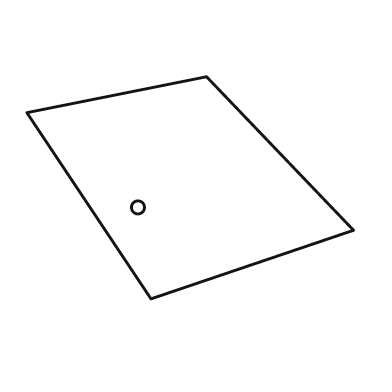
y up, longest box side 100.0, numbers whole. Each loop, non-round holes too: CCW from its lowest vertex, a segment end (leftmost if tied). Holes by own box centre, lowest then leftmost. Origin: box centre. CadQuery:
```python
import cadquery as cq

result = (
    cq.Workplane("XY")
    .moveTo(-12.0, -34.0)
    .lineTo(50.0, -13.0)
    .lineTo(5.0, 34.0)
    .lineTo(-50.0, 23.0)
    .close()
    .moveTo(-16.0, -6.0)
    .circle(2.0)
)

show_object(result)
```